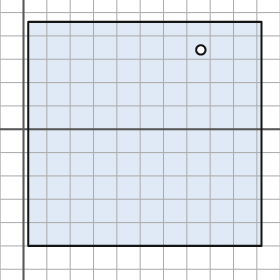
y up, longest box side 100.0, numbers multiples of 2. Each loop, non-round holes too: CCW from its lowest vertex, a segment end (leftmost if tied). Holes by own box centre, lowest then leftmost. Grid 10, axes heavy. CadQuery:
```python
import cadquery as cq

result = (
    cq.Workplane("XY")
    .moveTo(2.0, -50.0)
    .lineTo(102.0, -50.0)
    .lineTo(102.0, 46.0)
    .lineTo(2.0, 46.0)
    .close()
    .moveTo(76.0, 34.0)
    .circle(2.0)
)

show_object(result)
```